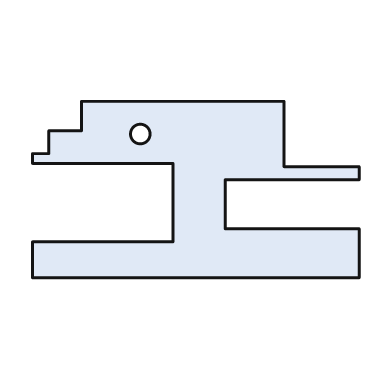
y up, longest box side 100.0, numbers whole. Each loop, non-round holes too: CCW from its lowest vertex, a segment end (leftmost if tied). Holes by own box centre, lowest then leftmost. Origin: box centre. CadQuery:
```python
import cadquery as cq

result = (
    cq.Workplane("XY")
    .moveTo(-50.0, -27.0)
    .lineTo(50.0, -27.0)
    .lineTo(50.0, -12.0)
    .lineTo(9.0, -12.0)
    .lineTo(9.0, 3.0)
    .lineTo(50.0, 3.0)
    .lineTo(50.0, 7.0)
    .lineTo(27.0, 7.0)
    .lineTo(27.0, 27.0)
    .lineTo(-35.0, 27.0)
    .lineTo(-35.0, 18.0)
    .lineTo(-45.0, 18.0)
    .lineTo(-45.0, 11.0)
    .lineTo(-50.0, 11.0)
    .lineTo(-50.0, 8.0)
    .lineTo(-7.0, 8.0)
    .lineTo(-7.0, -16.0)
    .lineTo(-50.0, -16.0)
    .close()
    .moveTo(-17.0, 17.0)
    .circle(3.0)
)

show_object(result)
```